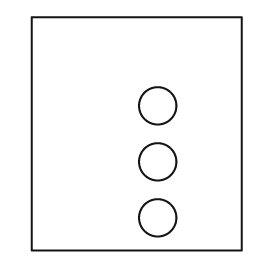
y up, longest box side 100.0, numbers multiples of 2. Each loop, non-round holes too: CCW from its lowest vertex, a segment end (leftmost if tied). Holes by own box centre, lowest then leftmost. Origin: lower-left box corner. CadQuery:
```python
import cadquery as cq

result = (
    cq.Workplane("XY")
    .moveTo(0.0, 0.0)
    .lineTo(90.0, 0.0)
    .lineTo(90.0, 100.0)
    .lineTo(0.0, 100.0)
    .close()
    .moveTo(54.0, 14.0)
    .circle(8.0)
    .moveTo(54.0, 38.0)
    .circle(8.0)
    .moveTo(54.0, 62.0)
    .circle(8.0)
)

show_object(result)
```